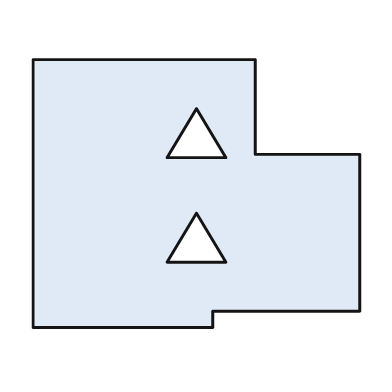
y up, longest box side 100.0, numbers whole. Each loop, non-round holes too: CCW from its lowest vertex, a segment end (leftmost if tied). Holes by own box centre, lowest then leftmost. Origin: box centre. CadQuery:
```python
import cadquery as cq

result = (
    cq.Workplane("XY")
    .moveTo(-50.0, -41.0)
    .lineTo(5.0, -41.0)
    .lineTo(5.0, -36.0)
    .lineTo(50.0, -36.0)
    .lineTo(50.0, 12.0)
    .lineTo(18.0, 12.0)
    .lineTo(18.0, 41.0)
    .lineTo(-50.0, 41.0)
    .close()
    .moveTo(-9.0, -21.0)
    .lineTo(9.0, -21.0)
    .lineTo(0.0, -6.0)
    .close()
    .moveTo(-9.0, 11.0)
    .lineTo(9.0, 11.0)
    .lineTo(0.0, 26.0)
    .close()
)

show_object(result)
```